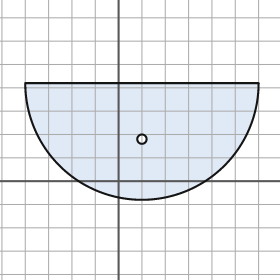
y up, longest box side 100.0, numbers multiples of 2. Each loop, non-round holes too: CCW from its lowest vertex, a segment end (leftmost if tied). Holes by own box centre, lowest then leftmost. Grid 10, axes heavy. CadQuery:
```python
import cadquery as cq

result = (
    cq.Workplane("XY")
    .moveTo(-40.0, 42.0)
    .threePointArc((10.0, -8.0), (60.0, 42.0))
    .close()
    .moveTo(10.0, 18.0)
    .circle(2.0)
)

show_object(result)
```